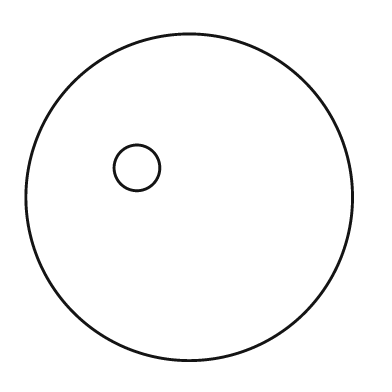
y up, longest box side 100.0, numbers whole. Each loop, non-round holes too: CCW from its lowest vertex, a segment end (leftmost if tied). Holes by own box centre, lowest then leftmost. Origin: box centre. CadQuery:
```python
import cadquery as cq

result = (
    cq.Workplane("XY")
    .moveTo(0.0, 0.0)
    .circle(50.0)
    .moveTo(-16.0, 9.0)
    .circle(7.0)
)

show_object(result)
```